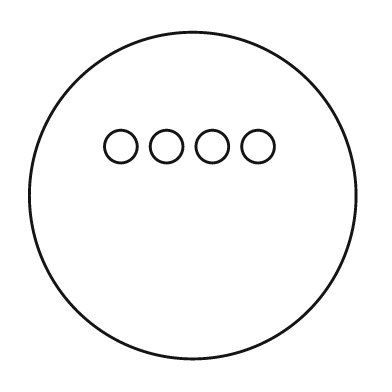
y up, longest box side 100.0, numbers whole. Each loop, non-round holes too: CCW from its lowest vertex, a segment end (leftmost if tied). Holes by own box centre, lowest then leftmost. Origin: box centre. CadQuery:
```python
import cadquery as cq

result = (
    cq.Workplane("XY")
    .moveTo(0.0, 0.0)
    .circle(50.0)
    .moveTo(-22.0, 15.0)
    .circle(5.0)
    .moveTo(-8.0, 15.0)
    .circle(5.0)
    .moveTo(6.0, 15.0)
    .circle(5.0)
    .moveTo(20.0, 15.0)
    .circle(5.0)
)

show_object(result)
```